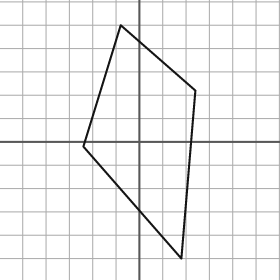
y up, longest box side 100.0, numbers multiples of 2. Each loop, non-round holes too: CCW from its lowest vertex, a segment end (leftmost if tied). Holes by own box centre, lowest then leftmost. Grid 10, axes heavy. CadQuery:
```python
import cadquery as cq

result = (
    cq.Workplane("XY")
    .moveTo(18.0, -50.0)
    .lineTo(24.0, 22.0)
    .lineTo(-8.0, 50.0)
    .lineTo(-24.0, -2.0)
    .close()
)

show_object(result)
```